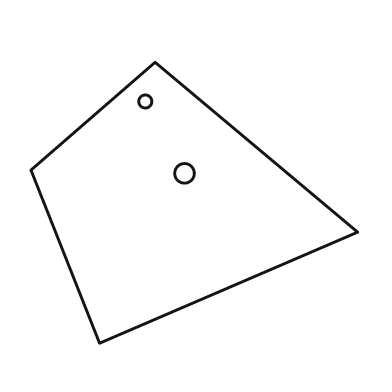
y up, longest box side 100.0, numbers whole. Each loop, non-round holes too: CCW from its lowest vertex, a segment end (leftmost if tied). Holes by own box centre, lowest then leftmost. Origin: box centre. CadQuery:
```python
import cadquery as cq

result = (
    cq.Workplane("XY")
    .moveTo(-29.0, -43.0)
    .lineTo(50.0, -9.0)
    .lineTo(-12.0, 43.0)
    .lineTo(-50.0, 10.0)
    .close()
    .moveTo(-3.0, 9.0)
    .circle(3.0)
    .moveTo(-15.0, 31.0)
    .circle(2.0)
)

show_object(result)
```